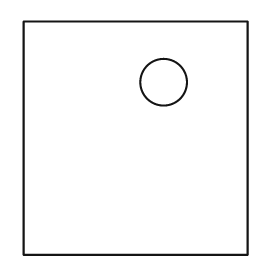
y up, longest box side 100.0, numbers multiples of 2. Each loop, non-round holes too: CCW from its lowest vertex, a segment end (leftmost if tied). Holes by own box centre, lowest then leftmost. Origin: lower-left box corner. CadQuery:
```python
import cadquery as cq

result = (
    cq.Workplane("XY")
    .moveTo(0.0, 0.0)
    .lineTo(96.0, 0.0)
    .lineTo(96.0, 100.0)
    .lineTo(0.0, 100.0)
    .close()
    .moveTo(60.0, 74.0)
    .circle(10.0)
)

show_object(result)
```